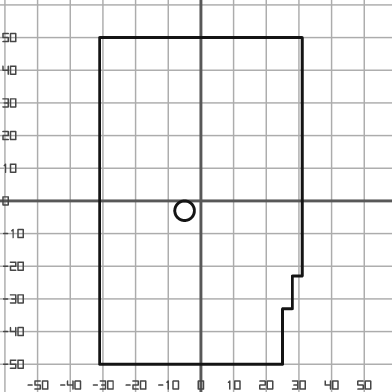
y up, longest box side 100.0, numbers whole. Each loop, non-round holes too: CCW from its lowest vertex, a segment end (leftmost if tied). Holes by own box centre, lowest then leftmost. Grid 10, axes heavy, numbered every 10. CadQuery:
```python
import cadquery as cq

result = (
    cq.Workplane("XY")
    .moveTo(-31.0, -50.0)
    .lineTo(25.0, -50.0)
    .lineTo(25.0, -33.0)
    .lineTo(28.0, -33.0)
    .lineTo(28.0, -23.0)
    .lineTo(31.0, -23.0)
    .lineTo(31.0, 50.0)
    .lineTo(-31.0, 50.0)
    .close()
    .moveTo(-5.0, -3.0)
    .circle(3.0)
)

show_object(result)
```